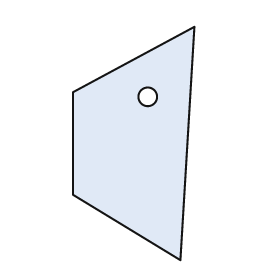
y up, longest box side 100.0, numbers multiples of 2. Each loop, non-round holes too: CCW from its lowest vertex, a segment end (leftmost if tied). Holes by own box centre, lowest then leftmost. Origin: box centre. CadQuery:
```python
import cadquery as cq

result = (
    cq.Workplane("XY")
    .moveTo(20.0, -50.0)
    .lineTo(26.0, 50.0)
    .lineTo(-26.0, 22.0)
    .lineTo(-26.0, -22.0)
    .close()
    .moveTo(6.0, 20.0)
    .circle(4.0)
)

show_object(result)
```